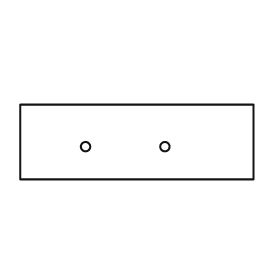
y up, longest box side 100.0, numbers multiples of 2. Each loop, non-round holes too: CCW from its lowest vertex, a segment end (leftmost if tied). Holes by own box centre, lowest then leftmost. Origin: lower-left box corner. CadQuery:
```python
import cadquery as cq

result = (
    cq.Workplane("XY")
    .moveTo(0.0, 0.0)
    .lineTo(100.0, 0.0)
    .lineTo(100.0, 32.0)
    .lineTo(0.0, 32.0)
    .close()
    .moveTo(28.0, 14.0)
    .circle(2.0)
    .moveTo(62.0, 14.0)
    .circle(2.0)
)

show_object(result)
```